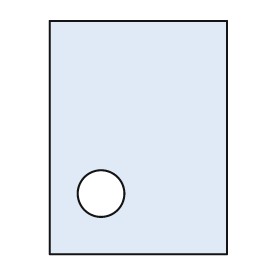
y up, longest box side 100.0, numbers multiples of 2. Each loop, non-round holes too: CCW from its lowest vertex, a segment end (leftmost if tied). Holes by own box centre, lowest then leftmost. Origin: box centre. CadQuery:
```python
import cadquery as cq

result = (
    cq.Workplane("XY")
    .moveTo(-38.0, -50.0)
    .lineTo(38.0, -50.0)
    .lineTo(38.0, 50.0)
    .lineTo(-38.0, 50.0)
    .close()
    .moveTo(-16.0, -24.0)
    .circle(10.0)
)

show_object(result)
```